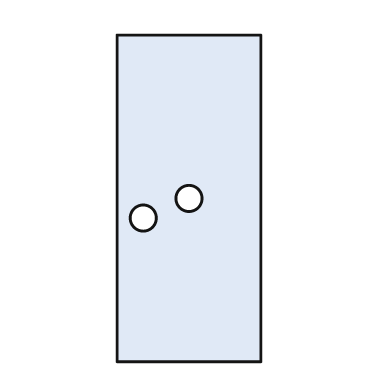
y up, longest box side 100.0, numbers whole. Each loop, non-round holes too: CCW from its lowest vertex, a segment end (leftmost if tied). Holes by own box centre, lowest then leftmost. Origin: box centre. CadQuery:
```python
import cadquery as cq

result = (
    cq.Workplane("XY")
    .moveTo(-22.0, -50.0)
    .lineTo(22.0, -50.0)
    .lineTo(22.0, 50.0)
    .lineTo(-22.0, 50.0)
    .close()
    .moveTo(-14.0, -6.0)
    .circle(4.0)
    .moveTo(0.0, 0.0)
    .circle(4.0)
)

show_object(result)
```